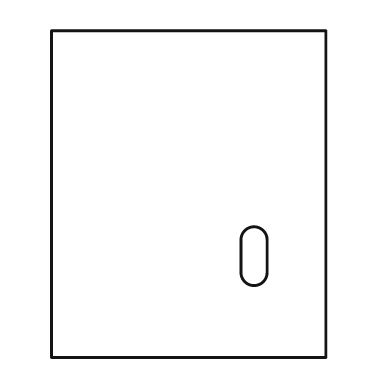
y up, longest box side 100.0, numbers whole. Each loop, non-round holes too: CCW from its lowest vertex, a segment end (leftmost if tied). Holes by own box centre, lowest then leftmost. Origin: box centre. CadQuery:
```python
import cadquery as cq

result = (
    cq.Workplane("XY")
    .moveTo(-42.0, -50.0)
    .lineTo(42.0, -50.0)
    .lineTo(42.0, 50.0)
    .lineTo(-42.0, 50.0)
    .close()
    .moveTo(16.0, -24.0)
    .threePointArc((20.0, -28.0), (24.0, -24.0))
    .lineTo(24.0, -14.0)
    .threePointArc((20.0, -10.0), (16.0, -14.0))
    .close()
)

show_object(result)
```